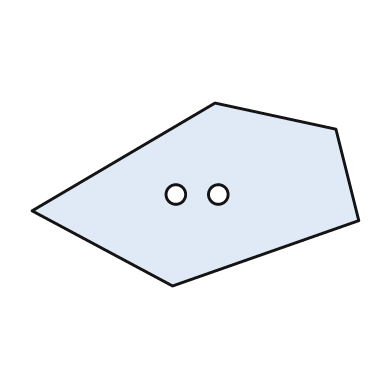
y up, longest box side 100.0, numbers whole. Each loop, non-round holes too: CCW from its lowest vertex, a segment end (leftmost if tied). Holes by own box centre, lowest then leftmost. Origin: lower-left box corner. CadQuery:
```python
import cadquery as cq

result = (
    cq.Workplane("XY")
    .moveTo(43.0, 0.0)
    .lineTo(100.0, 20.0)
    .lineTo(93.0, 48.0)
    .lineTo(56.0, 56.0)
    .lineTo(0.0, 23.0)
    .close()
    .moveTo(44.0, 28.0)
    .circle(3.0)
    .moveTo(57.0, 28.0)
    .circle(3.0)
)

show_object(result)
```